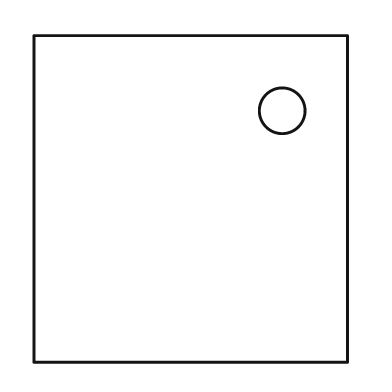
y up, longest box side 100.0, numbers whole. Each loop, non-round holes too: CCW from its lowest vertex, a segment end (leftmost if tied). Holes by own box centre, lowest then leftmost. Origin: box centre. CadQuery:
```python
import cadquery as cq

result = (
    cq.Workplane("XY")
    .moveTo(-48.0, -50.0)
    .lineTo(48.0, -50.0)
    .lineTo(48.0, 50.0)
    .lineTo(-48.0, 50.0)
    .close()
    .moveTo(28.0, 27.0)
    .circle(7.0)
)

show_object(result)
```